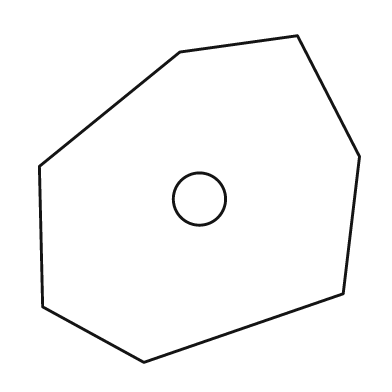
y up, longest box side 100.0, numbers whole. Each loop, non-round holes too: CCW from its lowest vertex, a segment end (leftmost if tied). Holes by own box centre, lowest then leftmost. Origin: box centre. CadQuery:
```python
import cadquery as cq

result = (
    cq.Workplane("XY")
    .moveTo(-17.0, -50.0)
    .lineTo(44.0, -29.0)
    .lineTo(49.0, 13.0)
    .lineTo(30.0, 50.0)
    .lineTo(-6.0, 45.0)
    .lineTo(-49.0, 10.0)
    .lineTo(-48.0, -33.0)
    .close()
    .moveTo(0.0, 0.0)
    .circle(8.0)
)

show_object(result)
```